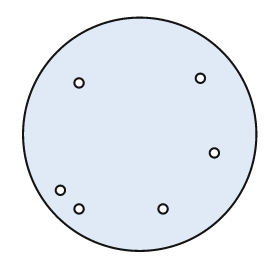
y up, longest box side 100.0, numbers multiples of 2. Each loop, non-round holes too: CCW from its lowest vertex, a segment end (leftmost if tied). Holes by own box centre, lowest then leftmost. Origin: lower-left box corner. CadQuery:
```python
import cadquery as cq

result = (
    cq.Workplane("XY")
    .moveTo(50.0, 50.0)
    .circle(50.0)
    .moveTo(24.0, 18.0)
    .circle(2.0)
    .moveTo(60.0, 18.0)
    .circle(2.0)
    .moveTo(16.0, 26.0)
    .circle(2.0)
    .moveTo(82.0, 42.0)
    .circle(2.0)
    .moveTo(24.0, 72.0)
    .circle(2.0)
    .moveTo(76.0, 74.0)
    .circle(2.0)
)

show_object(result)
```